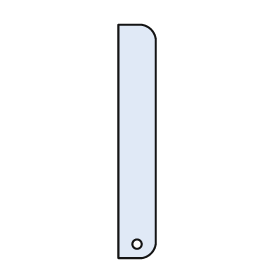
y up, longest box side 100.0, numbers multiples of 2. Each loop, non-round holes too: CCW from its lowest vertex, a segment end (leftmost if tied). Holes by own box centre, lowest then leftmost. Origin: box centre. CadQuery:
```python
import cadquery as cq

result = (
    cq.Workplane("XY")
    .moveTo(-8.0, -50.0)
    .lineTo(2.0, -50.0)
    .threePointArc((6.0, -48.0), (8.0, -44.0))
    .lineTo(8.0, 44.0)
    .threePointArc((6.0, 48.0), (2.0, 50.0))
    .lineTo(-8.0, 50.0)
    .close()
    .moveTo(0.0, -44.0)
    .circle(2.0)
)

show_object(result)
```